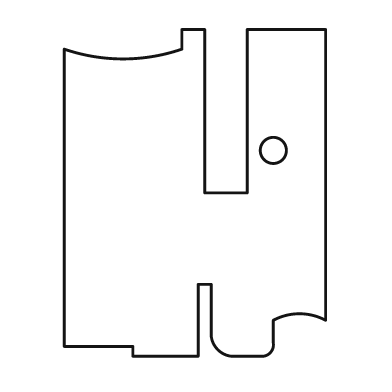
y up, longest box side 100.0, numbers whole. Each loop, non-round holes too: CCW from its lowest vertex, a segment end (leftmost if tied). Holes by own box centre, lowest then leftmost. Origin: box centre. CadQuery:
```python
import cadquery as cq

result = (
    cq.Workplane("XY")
    .moveTo(-19.0, -50.0)
    .lineTo(1.0, -50.0)
    .lineTo(1.0, -28.0)
    .lineTo(5.0, -28.0)
    .lineTo(5.0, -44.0)
    .threePointArc((7.0, -48.0), (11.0, -50.0))
    .lineTo(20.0, -50.0)
    .threePointArc((23.0, -49.0), (24.0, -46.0))
    .lineTo(24.0, -39.0)
    .threePointArc((32.0, -37.0), (40.0, -39.0))
    .lineTo(40.0, 50.0)
    .lineTo(16.0, 50.0)
    .lineTo(16.0, 0.0)
    .lineTo(3.0, 0.0)
    .lineTo(3.0, 50.0)
    .lineTo(-4.0, 50.0)
    .lineTo(-4.0, 44.0)
    .threePointArc((-22.0, 41.0), (-40.0, 44.0))
    .lineTo(-40.0, -47.0)
    .lineTo(-19.0, -47.0)
    .close()
    .moveTo(24.0, 13.0)
    .circle(4.0)
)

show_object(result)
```